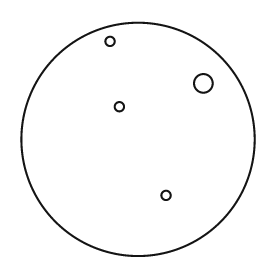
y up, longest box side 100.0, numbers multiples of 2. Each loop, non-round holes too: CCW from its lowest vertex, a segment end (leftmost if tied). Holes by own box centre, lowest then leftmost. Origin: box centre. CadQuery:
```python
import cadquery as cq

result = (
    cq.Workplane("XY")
    .moveTo(0.0, 0.0)
    .circle(50.0)
    .moveTo(12.0, -24.0)
    .circle(2.0)
    .moveTo(-8.0, 14.0)
    .circle(2.0)
    .moveTo(28.0, 24.0)
    .circle(4.0)
    .moveTo(-12.0, 42.0)
    .circle(2.0)
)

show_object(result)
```